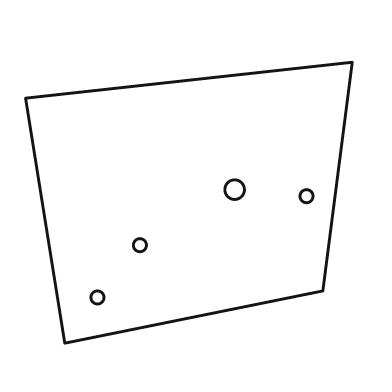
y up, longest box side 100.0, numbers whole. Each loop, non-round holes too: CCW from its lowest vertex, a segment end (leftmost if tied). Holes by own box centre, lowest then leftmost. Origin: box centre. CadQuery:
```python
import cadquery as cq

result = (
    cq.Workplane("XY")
    .moveTo(-38.0, -43.0)
    .lineTo(41.0, -27.0)
    .lineTo(50.0, 43.0)
    .lineTo(-50.0, 32.0)
    .close()
    .moveTo(-28.0, -29.0)
    .circle(2.0)
    .moveTo(-15.0, -13.0)
    .circle(2.0)
    .moveTo(36.0, 2.0)
    .circle(2.0)
    .moveTo(14.0, 4.0)
    .circle(3.0)
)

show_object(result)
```